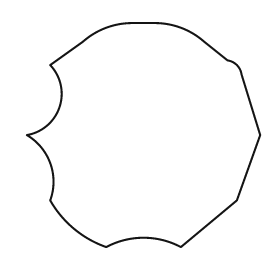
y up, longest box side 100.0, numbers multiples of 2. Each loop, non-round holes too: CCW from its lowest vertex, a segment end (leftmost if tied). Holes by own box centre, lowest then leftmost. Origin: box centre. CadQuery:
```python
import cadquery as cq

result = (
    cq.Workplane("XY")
    .moveTo(-16.0, -48.0)
    .threePointArc((0.0, -44.0), (16.0, -48.0))
    .lineTo(40.0, -28.0)
    .lineTo(50.0, 0.0)
    .lineTo(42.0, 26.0)
    .threePointArc((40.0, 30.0), (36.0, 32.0))
    .lineTo(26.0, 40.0)
    .threePointArc((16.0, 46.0), (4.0, 48.0))
    .lineTo(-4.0, 48.0)
    .threePointArc((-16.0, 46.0), (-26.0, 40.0))
    .lineTo(-40.0, 30.0)
    .threePointArc((-36.0, 12.0), (-50.0, 0.0))
    .threePointArc((-40.0, -12.0), (-40.0, -28.0))
    .threePointArc((-30.0, -40.0), (-16.0, -48.0))
    .close()
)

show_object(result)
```